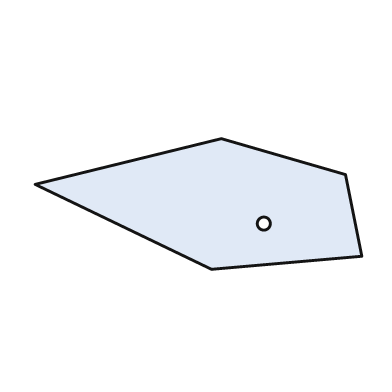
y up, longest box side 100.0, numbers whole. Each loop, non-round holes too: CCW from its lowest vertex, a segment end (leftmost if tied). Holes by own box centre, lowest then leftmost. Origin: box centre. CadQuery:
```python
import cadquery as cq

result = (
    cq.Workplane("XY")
    .moveTo(4.0, -20.0)
    .lineTo(50.0, -16.0)
    .lineTo(45.0, 9.0)
    .lineTo(7.0, 20.0)
    .lineTo(-50.0, 6.0)
    .close()
    .moveTo(20.0, -6.0)
    .circle(2.0)
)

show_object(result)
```